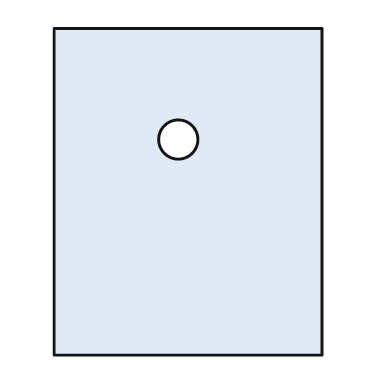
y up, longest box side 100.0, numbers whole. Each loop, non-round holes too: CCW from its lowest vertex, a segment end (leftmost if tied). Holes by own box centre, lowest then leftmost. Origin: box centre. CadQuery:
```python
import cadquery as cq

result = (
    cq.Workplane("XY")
    .moveTo(-41.0, -50.0)
    .lineTo(41.0, -50.0)
    .lineTo(41.0, 50.0)
    .lineTo(-41.0, 50.0)
    .close()
    .moveTo(-3.0, 16.0)
    .circle(6.0)
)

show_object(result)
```